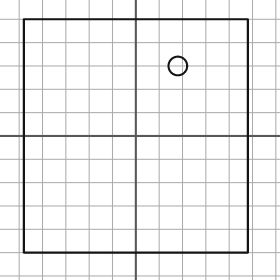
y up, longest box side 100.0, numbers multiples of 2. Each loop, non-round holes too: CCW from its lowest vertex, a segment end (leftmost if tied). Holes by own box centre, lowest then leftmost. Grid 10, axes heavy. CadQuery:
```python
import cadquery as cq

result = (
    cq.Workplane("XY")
    .moveTo(-48.0, -50.0)
    .lineTo(48.0, -50.0)
    .lineTo(48.0, 50.0)
    .lineTo(-48.0, 50.0)
    .close()
    .moveTo(18.0, 30.0)
    .circle(4.0)
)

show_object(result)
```